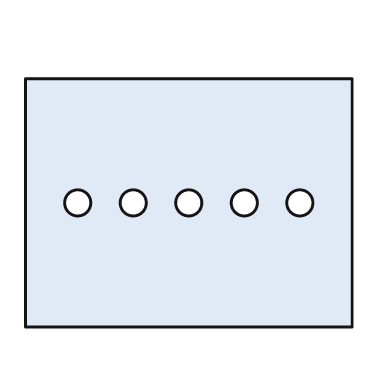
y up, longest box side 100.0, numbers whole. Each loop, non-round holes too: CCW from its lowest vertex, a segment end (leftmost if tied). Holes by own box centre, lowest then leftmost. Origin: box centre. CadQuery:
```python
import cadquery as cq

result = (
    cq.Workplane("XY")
    .moveTo(-50.0, -38.0)
    .lineTo(50.0, -38.0)
    .lineTo(50.0, 38.0)
    .lineTo(-50.0, 38.0)
    .close()
    .moveTo(-34.0, 0.0)
    .circle(4.0)
    .moveTo(-17.0, 0.0)
    .circle(4.0)
    .moveTo(0.0, 0.0)
    .circle(4.0)
    .moveTo(17.0, 0.0)
    .circle(4.0)
    .moveTo(34.0, 0.0)
    .circle(4.0)
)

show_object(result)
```